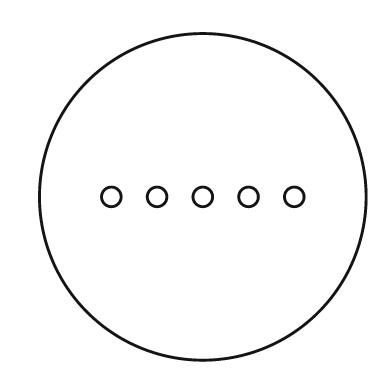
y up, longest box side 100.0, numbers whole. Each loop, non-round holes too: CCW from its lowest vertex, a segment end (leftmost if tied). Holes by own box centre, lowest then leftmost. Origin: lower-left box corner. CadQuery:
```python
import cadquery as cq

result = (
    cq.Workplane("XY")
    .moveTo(50.0, 50.0)
    .circle(50.0)
    .moveTo(22.0, 50.0)
    .circle(3.0)
    .moveTo(36.0, 50.0)
    .circle(3.0)
    .moveTo(50.0, 50.0)
    .circle(3.0)
    .moveTo(64.0, 50.0)
    .circle(3.0)
    .moveTo(78.0, 50.0)
    .circle(3.0)
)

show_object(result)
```